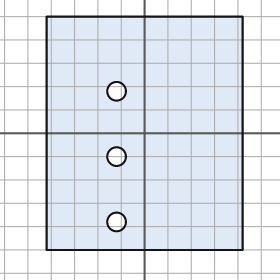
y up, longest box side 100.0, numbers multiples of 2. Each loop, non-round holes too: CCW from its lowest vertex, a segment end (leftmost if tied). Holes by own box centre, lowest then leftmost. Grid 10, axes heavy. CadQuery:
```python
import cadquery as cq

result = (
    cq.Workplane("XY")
    .moveTo(-42.0, -50.0)
    .lineTo(42.0, -50.0)
    .lineTo(42.0, 50.0)
    .lineTo(-42.0, 50.0)
    .close()
    .moveTo(-12.0, -38.0)
    .circle(4.0)
    .moveTo(-12.0, -10.0)
    .circle(4.0)
    .moveTo(-12.0, 18.0)
    .circle(4.0)
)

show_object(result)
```